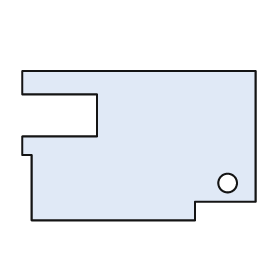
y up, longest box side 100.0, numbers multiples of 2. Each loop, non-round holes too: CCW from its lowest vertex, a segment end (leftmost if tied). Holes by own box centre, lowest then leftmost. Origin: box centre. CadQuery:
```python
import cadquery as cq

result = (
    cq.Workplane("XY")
    .moveTo(-46.0, -32.0)
    .lineTo(24.0, -32.0)
    .lineTo(24.0, -24.0)
    .lineTo(50.0, -24.0)
    .lineTo(50.0, 32.0)
    .lineTo(-50.0, 32.0)
    .lineTo(-50.0, 22.0)
    .lineTo(-18.0, 22.0)
    .lineTo(-18.0, 4.0)
    .lineTo(-50.0, 4.0)
    .lineTo(-50.0, -4.0)
    .lineTo(-46.0, -4.0)
    .close()
    .moveTo(38.0, -16.0)
    .circle(4.0)
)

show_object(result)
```